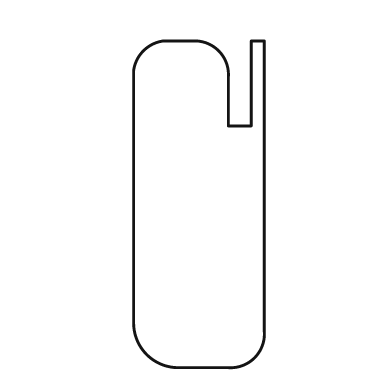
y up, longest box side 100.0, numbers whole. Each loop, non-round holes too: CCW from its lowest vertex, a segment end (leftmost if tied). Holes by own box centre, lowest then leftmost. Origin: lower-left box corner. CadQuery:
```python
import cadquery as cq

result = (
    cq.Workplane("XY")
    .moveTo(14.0, 0.0)
    .lineTo(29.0, 0.0)
    .threePointArc((37.0, 3.0), (40.0, 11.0))
    .lineTo(40.0, 100.0)
    .lineTo(36.0, 100.0)
    .lineTo(36.0, 74.0)
    .lineTo(29.0, 74.0)
    .lineTo(29.0, 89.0)
    .threePointArc((26.0, 97.0), (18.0, 100.0))
    .lineTo(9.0, 100.0)
    .threePointArc((3.0, 97.0), (0.0, 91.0))
    .lineTo(0.0, 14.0)
    .threePointArc((4.0, 4.0), (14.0, 0.0))
    .close()
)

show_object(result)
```